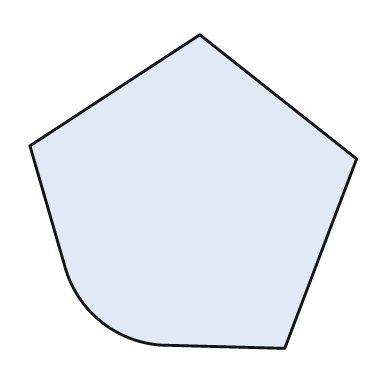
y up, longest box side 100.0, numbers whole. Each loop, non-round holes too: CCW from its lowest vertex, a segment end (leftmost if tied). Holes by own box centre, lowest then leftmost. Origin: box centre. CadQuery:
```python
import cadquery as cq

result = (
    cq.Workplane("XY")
    .moveTo(28.0, -48.0)
    .lineTo(50.0, 10.0)
    .lineTo(2.0, 48.0)
    .lineTo(-50.0, 14.0)
    .lineTo(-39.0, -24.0)
    .threePointArc((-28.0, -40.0), (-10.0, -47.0))
    .close()
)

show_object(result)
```